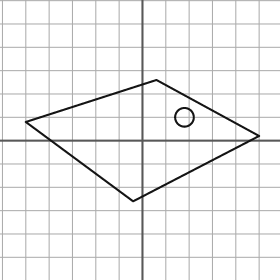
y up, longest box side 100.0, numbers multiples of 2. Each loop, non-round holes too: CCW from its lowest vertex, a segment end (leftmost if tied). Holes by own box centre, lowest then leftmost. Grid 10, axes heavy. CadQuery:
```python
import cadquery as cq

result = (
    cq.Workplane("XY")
    .moveTo(-4.0, -26.0)
    .lineTo(50.0, 2.0)
    .lineTo(6.0, 26.0)
    .lineTo(-50.0, 8.0)
    .close()
    .moveTo(18.0, 10.0)
    .circle(4.0)
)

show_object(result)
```